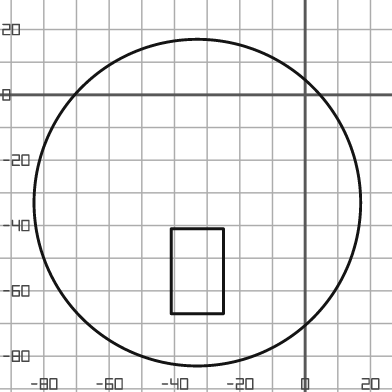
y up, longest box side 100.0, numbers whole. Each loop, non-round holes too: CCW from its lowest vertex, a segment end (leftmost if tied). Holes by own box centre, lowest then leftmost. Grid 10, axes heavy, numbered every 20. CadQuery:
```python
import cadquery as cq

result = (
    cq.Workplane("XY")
    .moveTo(-33.0, -33.0)
    .circle(50.0)
    .moveTo(-41.0, -67.0)
    .lineTo(-25.0, -67.0)
    .lineTo(-25.0, -41.0)
    .lineTo(-41.0, -41.0)
    .close()
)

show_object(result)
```